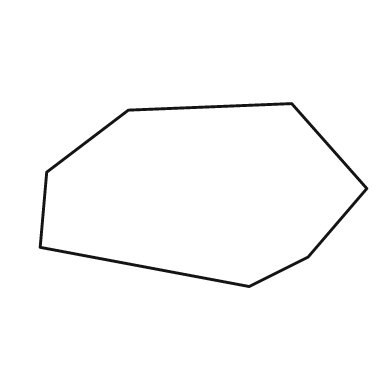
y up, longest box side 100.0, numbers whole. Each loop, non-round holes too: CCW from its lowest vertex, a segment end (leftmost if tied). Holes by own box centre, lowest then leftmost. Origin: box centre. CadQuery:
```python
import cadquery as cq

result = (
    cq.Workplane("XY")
    .moveTo(14.0, -28.0)
    .lineTo(32.0, -19.0)
    .lineTo(50.0, 2.0)
    .lineTo(27.0, 28.0)
    .lineTo(-23.0, 26.0)
    .lineTo(-48.0, 7.0)
    .lineTo(-50.0, -16.0)
    .close()
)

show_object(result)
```